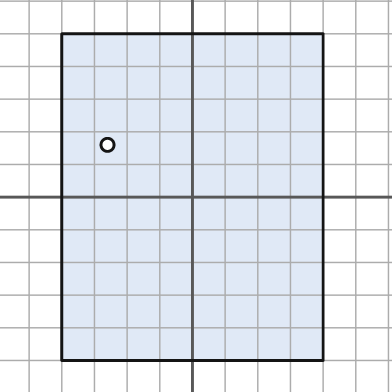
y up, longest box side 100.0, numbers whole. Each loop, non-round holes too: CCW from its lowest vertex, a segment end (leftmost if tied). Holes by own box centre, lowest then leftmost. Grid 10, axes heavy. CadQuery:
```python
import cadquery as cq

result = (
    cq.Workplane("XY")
    .moveTo(-40.0, -50.0)
    .lineTo(40.0, -50.0)
    .lineTo(40.0, 50.0)
    .lineTo(-40.0, 50.0)
    .close()
    .moveTo(-26.0, 16.0)
    .circle(2.0)
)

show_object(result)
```